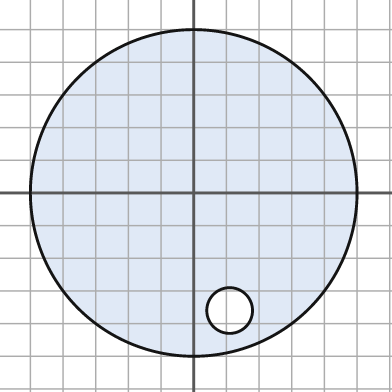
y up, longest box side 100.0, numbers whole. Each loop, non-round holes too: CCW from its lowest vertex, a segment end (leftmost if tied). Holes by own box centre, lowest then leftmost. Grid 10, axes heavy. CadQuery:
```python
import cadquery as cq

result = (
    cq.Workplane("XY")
    .moveTo(0.0, 0.0)
    .circle(50.0)
    .moveTo(11.0, -36.0)
    .circle(7.0)
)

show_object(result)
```